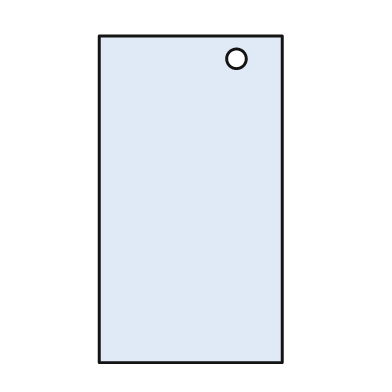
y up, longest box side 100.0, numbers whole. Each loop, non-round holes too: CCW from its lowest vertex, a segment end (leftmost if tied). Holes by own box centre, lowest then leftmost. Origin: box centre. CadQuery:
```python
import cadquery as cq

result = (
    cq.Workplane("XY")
    .moveTo(-28.0, -50.0)
    .lineTo(28.0, -50.0)
    .lineTo(28.0, 50.0)
    .lineTo(-28.0, 50.0)
    .close()
    .moveTo(14.0, 43.0)
    .circle(3.0)
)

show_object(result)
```